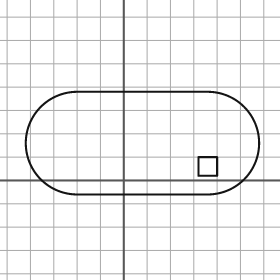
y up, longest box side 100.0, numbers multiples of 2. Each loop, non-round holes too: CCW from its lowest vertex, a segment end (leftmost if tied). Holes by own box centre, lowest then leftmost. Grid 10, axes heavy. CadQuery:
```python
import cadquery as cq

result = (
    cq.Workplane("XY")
    .moveTo(-20.0, -6.0)
    .lineTo(36.0, -6.0)
    .threePointArc((58.0, 16.0), (36.0, 38.0))
    .lineTo(-20.0, 38.0)
    .threePointArc((-42.0, 16.0), (-20.0, -6.0))
    .close()
    .moveTo(32.0, 2.0)
    .lineTo(40.0, 2.0)
    .lineTo(40.0, 10.0)
    .lineTo(32.0, 10.0)
    .close()
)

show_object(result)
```